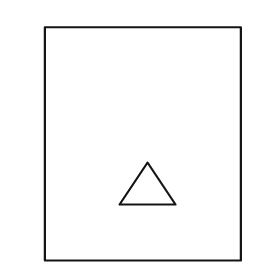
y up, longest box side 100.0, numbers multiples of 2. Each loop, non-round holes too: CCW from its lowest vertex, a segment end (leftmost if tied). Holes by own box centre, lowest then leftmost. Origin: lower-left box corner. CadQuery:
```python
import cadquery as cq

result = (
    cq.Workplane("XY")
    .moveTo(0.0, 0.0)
    .lineTo(84.0, 0.0)
    .lineTo(84.0, 100.0)
    .lineTo(0.0, 100.0)
    .close()
    .moveTo(32.0, 24.0)
    .lineTo(56.0, 24.0)
    .lineTo(44.0, 42.0)
    .close()
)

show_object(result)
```